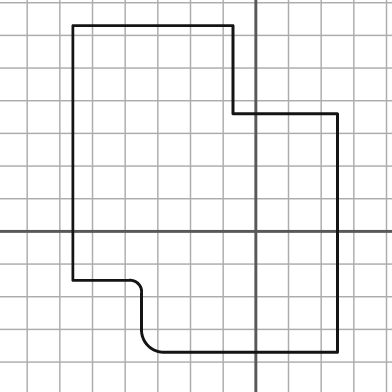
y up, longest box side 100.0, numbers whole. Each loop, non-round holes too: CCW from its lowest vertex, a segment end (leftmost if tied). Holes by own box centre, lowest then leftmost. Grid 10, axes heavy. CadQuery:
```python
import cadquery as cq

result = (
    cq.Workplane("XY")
    .moveTo(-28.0, -37.0)
    .lineTo(25.0, -37.0)
    .lineTo(25.0, 36.0)
    .lineTo(-7.0, 36.0)
    .lineTo(-7.0, 63.0)
    .lineTo(-56.0, 63.0)
    .lineTo(-56.0, -15.0)
    .lineTo(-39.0, -15.0)
    .threePointArc((-36.0, -16.0), (-35.0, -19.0))
    .lineTo(-35.0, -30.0)
    .threePointArc((-33.0, -35.0), (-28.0, -37.0))
    .close()
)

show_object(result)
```